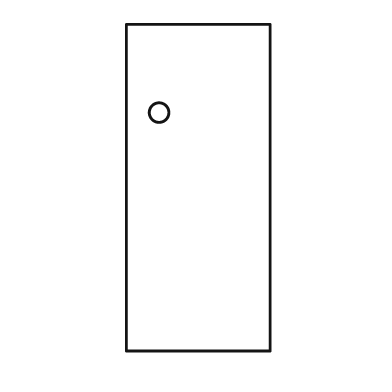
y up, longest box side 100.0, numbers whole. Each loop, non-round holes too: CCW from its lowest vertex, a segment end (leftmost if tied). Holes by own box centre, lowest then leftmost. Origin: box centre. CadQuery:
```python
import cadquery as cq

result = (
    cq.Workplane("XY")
    .moveTo(-22.0, -50.0)
    .lineTo(22.0, -50.0)
    .lineTo(22.0, 50.0)
    .lineTo(-22.0, 50.0)
    .close()
    .moveTo(-12.0, 23.0)
    .circle(3.0)
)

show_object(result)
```